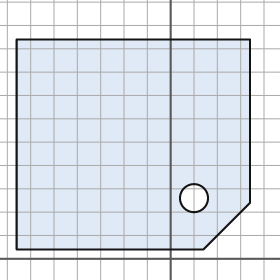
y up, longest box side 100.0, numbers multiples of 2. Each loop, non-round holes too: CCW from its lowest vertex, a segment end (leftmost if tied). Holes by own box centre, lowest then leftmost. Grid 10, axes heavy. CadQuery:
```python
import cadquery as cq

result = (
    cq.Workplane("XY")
    .moveTo(-66.0, 4.0)
    .lineTo(14.0, 4.0)
    .lineTo(34.0, 24.0)
    .lineTo(34.0, 94.0)
    .lineTo(-66.0, 94.0)
    .close()
    .moveTo(10.0, 26.0)
    .circle(6.0)
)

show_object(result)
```